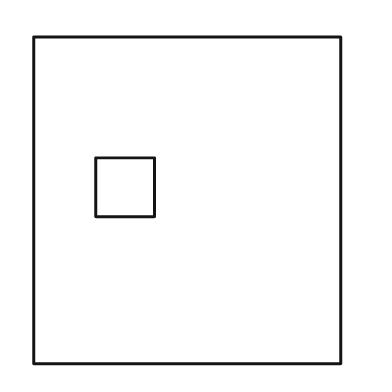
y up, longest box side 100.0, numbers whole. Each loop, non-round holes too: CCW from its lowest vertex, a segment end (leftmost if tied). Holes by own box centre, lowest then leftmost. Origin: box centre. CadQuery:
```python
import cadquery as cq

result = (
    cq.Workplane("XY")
    .moveTo(-47.0, -50.0)
    .lineTo(47.0, -50.0)
    .lineTo(47.0, 50.0)
    .lineTo(-47.0, 50.0)
    .close()
    .moveTo(-28.0, -5.0)
    .lineTo(-10.0, -5.0)
    .lineTo(-10.0, 13.0)
    .lineTo(-28.0, 13.0)
    .close()
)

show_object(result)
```